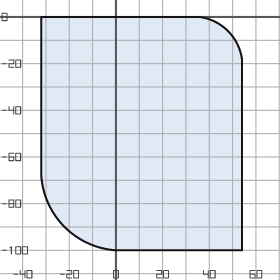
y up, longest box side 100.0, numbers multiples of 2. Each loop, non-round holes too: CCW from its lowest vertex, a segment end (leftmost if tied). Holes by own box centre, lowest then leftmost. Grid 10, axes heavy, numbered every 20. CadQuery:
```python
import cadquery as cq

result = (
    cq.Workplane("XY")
    .moveTo(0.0, -100.0)
    .lineTo(54.0, -100.0)
    .lineTo(54.0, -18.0)
    .threePointArc((48.0, -6.0), (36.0, 0.0))
    .lineTo(-32.0, 0.0)
    .lineTo(-32.0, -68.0)
    .threePointArc((-22.0, -90.0), (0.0, -100.0))
    .close()
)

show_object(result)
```